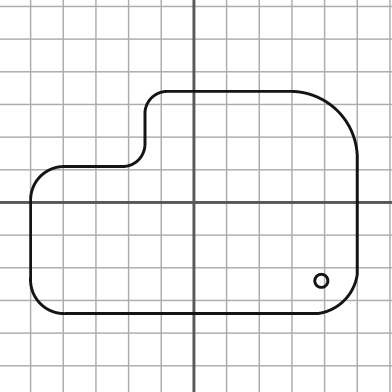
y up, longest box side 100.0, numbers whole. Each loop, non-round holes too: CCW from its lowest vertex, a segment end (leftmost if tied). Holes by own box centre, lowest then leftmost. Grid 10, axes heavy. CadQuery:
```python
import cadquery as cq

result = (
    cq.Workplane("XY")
    .moveTo(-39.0, -34.0)
    .lineTo(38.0, -34.0)
    .threePointArc((46.0, -30.0), (50.0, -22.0))
    .lineTo(50.0, 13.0)
    .threePointArc((44.0, 28.0), (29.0, 34.0))
    .lineTo(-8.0, 34.0)
    .threePointArc((-13.0, 32.0), (-15.0, 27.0))
    .lineTo(-15.0, 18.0)
    .threePointArc((-17.0, 13.0), (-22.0, 11.0))
    .lineTo(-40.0, 11.0)
    .threePointArc((-47.0, 8.0), (-50.0, 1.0))
    .lineTo(-50.0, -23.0)
    .threePointArc((-47.0, -31.0), (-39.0, -34.0))
    .close()
    .moveTo(39.0, -24.0)
    .circle(2.0)
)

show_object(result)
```